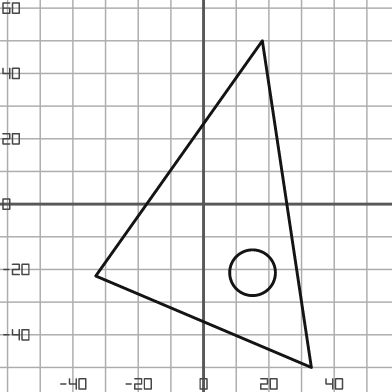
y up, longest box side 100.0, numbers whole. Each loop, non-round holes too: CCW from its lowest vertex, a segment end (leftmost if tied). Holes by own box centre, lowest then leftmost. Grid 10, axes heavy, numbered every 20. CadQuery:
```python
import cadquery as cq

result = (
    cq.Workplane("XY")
    .moveTo(33.0, -50.0)
    .lineTo(18.0, 50.0)
    .lineTo(-33.0, -22.0)
    .close()
    .moveTo(15.0, -21.0)
    .circle(7.0)
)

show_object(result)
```